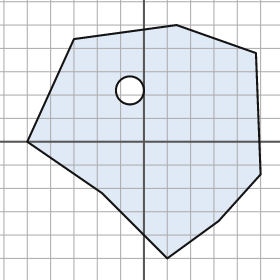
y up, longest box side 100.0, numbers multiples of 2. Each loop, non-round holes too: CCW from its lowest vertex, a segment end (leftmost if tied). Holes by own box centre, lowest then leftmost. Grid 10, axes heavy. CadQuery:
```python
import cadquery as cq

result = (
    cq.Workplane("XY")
    .moveTo(10.0, -50.0)
    .lineTo(32.0, -34.0)
    .lineTo(50.0, -14.0)
    .lineTo(48.0, 38.0)
    .lineTo(14.0, 50.0)
    .lineTo(-30.0, 44.0)
    .lineTo(-50.0, 0.0)
    .lineTo(-18.0, -22.0)
    .close()
    .moveTo(-6.0, 22.0)
    .circle(6.0)
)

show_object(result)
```